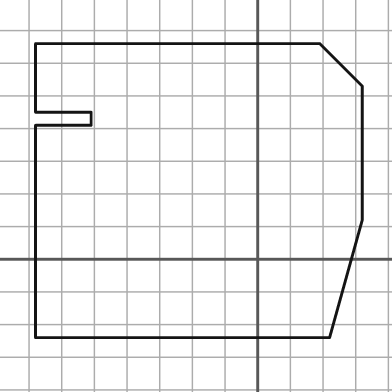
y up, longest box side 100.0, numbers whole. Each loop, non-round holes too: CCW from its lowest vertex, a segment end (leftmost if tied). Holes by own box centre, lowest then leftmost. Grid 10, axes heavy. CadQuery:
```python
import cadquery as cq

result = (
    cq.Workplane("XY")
    .moveTo(-68.0, -24.0)
    .lineTo(22.0, -24.0)
    .lineTo(32.0, 12.0)
    .lineTo(32.0, 53.0)
    .lineTo(19.0, 66.0)
    .lineTo(-68.0, 66.0)
    .lineTo(-68.0, 45.0)
    .lineTo(-51.0, 45.0)
    .lineTo(-51.0, 41.0)
    .lineTo(-68.0, 41.0)
    .close()
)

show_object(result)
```